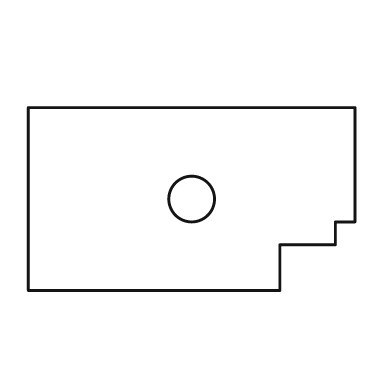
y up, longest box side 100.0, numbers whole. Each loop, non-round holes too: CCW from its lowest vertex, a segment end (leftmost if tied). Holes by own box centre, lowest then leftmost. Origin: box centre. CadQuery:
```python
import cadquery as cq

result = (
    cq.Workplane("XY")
    .moveTo(-50.0, -28.0)
    .lineTo(27.0, -28.0)
    .lineTo(27.0, -14.0)
    .lineTo(44.0, -14.0)
    .lineTo(44.0, -7.0)
    .lineTo(50.0, -7.0)
    .lineTo(50.0, 28.0)
    .lineTo(-50.0, 28.0)
    .close()
    .moveTo(0.0, 0.0)
    .circle(7.0)
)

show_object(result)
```